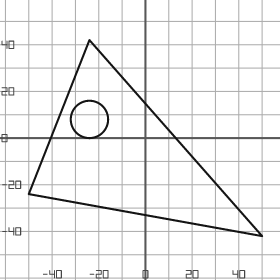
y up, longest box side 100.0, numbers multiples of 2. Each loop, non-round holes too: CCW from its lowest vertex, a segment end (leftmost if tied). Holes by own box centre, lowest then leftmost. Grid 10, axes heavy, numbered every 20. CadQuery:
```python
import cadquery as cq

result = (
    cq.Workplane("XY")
    .moveTo(50.0, -42.0)
    .lineTo(-24.0, 42.0)
    .lineTo(-50.0, -24.0)
    .close()
    .moveTo(-24.0, 8.0)
    .circle(8.0)
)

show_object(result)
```